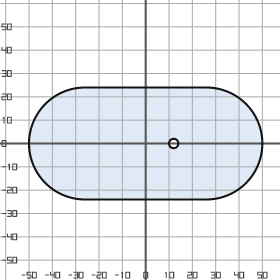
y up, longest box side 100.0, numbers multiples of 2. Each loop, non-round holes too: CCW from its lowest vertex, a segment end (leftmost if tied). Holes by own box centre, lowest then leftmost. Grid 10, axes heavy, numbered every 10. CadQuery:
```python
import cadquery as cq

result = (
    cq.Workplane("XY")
    .moveTo(-26.0, -24.0)
    .lineTo(26.0, -24.0)
    .threePointArc((50.0, 0.0), (26.0, 24.0))
    .lineTo(-26.0, 24.0)
    .threePointArc((-50.0, 0.0), (-26.0, -24.0))
    .close()
    .moveTo(12.0, 0.0)
    .circle(2.0)
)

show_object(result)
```